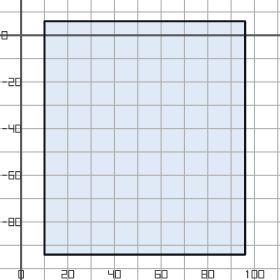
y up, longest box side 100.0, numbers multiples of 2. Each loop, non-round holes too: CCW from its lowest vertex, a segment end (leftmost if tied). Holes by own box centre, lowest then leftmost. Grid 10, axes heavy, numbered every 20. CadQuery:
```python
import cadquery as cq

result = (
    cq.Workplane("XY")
    .moveTo(10.0, -94.0)
    .lineTo(96.0, -94.0)
    .lineTo(96.0, 6.0)
    .lineTo(10.0, 6.0)
    .close()
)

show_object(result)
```